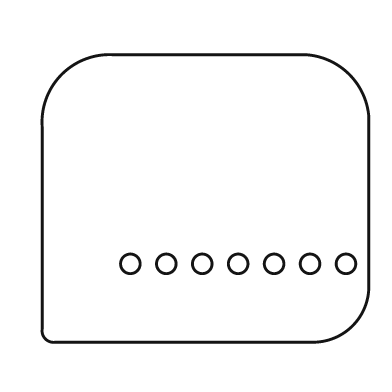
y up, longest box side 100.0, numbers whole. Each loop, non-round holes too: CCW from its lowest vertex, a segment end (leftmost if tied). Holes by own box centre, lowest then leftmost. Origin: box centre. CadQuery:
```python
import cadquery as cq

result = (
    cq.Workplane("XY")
    .moveTo(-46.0, -44.0)
    .lineTo(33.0, -44.0)
    .threePointArc((45.0, -39.0), (50.0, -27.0))
    .lineTo(50.0, 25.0)
    .threePointArc((44.0, 38.0), (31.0, 44.0))
    .lineTo(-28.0, 44.0)
    .threePointArc((-44.0, 38.0), (-50.0, 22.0))
    .lineTo(-50.0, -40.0)
    .threePointArc((-49.0, -43.0), (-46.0, -44.0))
    .close()
    .moveTo(-23.0, -20.0)
    .circle(3.0)
    .moveTo(-12.0, -20.0)
    .circle(3.0)
    .moveTo(-1.0, -20.0)
    .circle(3.0)
    .moveTo(10.0, -20.0)
    .circle(3.0)
    .moveTo(21.0, -20.0)
    .circle(3.0)
    .moveTo(32.0, -20.0)
    .circle(3.0)
    .moveTo(43.0, -20.0)
    .circle(3.0)
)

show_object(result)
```